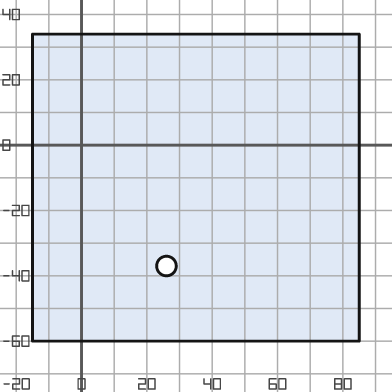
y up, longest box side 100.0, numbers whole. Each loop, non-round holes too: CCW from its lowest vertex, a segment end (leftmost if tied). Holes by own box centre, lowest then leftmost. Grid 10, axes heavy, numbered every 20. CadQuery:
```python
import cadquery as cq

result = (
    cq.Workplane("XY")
    .moveTo(-15.0, -60.0)
    .lineTo(85.0, -60.0)
    .lineTo(85.0, 34.0)
    .lineTo(-15.0, 34.0)
    .close()
    .moveTo(26.0, -37.0)
    .circle(3.0)
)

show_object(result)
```